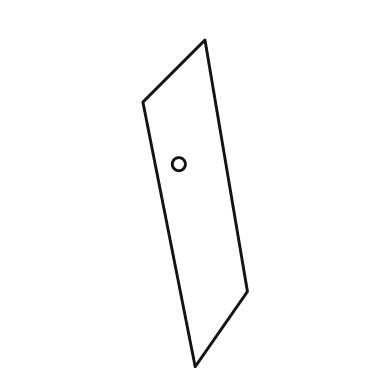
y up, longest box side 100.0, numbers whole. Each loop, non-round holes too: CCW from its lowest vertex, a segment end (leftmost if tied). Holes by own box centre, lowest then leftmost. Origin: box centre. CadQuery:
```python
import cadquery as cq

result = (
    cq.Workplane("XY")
    .moveTo(0.0, -50.0)
    .lineTo(16.0, -27.0)
    .lineTo(3.0, 50.0)
    .lineTo(-16.0, 31.0)
    .close()
    .moveTo(-5.0, 12.0)
    .circle(2.0)
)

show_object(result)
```